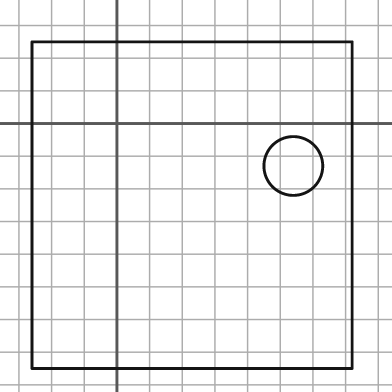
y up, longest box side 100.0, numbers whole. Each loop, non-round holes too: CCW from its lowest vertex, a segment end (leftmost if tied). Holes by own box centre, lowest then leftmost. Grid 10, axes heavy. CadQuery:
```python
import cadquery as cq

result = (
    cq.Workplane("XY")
    .moveTo(-26.0, -75.0)
    .lineTo(72.0, -75.0)
    .lineTo(72.0, 25.0)
    .lineTo(-26.0, 25.0)
    .close()
    .moveTo(54.0, -13.0)
    .circle(9.0)
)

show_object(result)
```